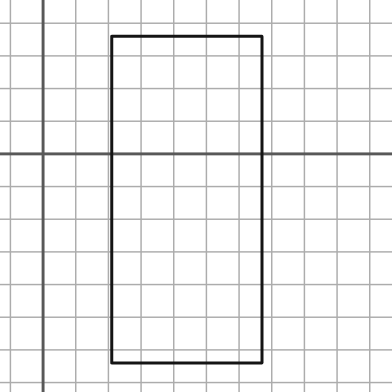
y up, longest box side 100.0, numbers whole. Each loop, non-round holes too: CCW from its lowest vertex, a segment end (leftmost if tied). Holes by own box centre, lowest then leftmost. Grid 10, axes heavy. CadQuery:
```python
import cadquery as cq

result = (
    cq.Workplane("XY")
    .moveTo(21.0, -64.0)
    .lineTo(67.0, -64.0)
    .lineTo(67.0, 36.0)
    .lineTo(21.0, 36.0)
    .close()
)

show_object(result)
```